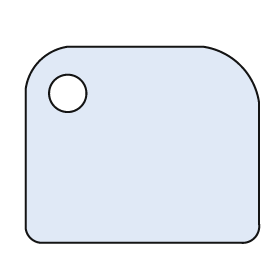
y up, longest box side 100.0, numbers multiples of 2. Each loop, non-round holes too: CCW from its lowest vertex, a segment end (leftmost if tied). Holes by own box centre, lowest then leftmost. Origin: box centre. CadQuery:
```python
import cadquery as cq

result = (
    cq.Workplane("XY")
    .moveTo(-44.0, -42.0)
    .lineTo(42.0, -42.0)
    .threePointArc((48.0, -40.0), (50.0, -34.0))
    .lineTo(50.0, 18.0)
    .threePointArc((42.0, 34.0), (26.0, 42.0))
    .lineTo(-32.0, 42.0)
    .threePointArc((-44.0, 36.0), (-50.0, 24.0))
    .lineTo(-50.0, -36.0)
    .threePointArc((-48.0, -40.0), (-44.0, -42.0))
    .close()
    .moveTo(-32.0, 22.0)
    .circle(8.0)
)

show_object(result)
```